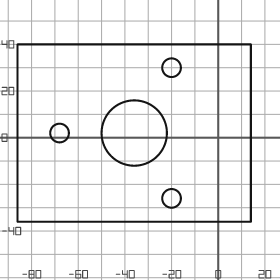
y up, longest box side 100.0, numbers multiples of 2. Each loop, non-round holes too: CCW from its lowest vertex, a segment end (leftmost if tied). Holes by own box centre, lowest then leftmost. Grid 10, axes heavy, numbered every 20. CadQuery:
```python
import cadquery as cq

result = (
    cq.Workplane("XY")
    .moveTo(-86.0, -36.0)
    .lineTo(14.0, -36.0)
    .lineTo(14.0, 40.0)
    .lineTo(-86.0, 40.0)
    .close()
    .moveTo(-20.0, -26.0)
    .circle(4.0)
    .moveTo(-68.0, 2.0)
    .circle(4.0)
    .moveTo(-36.0, 2.0)
    .circle(14.0)
    .moveTo(-20.0, 30.0)
    .circle(4.0)
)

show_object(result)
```